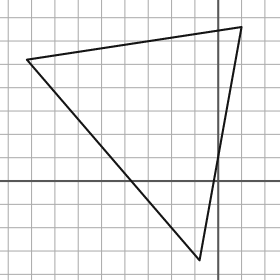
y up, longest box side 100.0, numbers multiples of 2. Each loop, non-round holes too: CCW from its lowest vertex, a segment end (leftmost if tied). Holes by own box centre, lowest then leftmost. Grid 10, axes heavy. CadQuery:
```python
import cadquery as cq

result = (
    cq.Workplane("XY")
    .moveTo(-8.0, -34.0)
    .lineTo(10.0, 66.0)
    .lineTo(-82.0, 52.0)
    .close()
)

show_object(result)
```